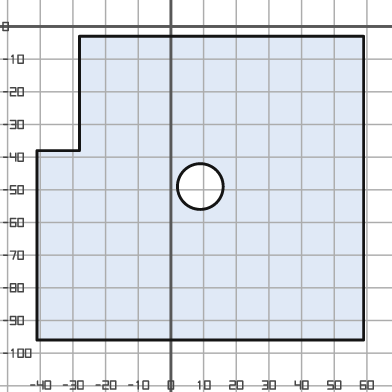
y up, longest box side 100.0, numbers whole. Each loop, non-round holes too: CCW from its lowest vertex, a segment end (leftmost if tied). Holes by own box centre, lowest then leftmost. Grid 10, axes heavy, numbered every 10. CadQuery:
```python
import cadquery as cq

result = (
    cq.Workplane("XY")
    .moveTo(-41.0, -96.0)
    .lineTo(59.0, -96.0)
    .lineTo(59.0, -3.0)
    .lineTo(-28.0, -3.0)
    .lineTo(-28.0, -38.0)
    .lineTo(-41.0, -38.0)
    .close()
    .moveTo(9.0, -49.0)
    .circle(7.0)
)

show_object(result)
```